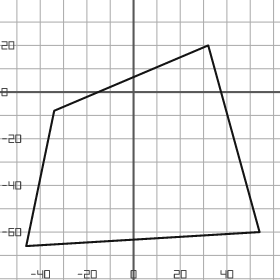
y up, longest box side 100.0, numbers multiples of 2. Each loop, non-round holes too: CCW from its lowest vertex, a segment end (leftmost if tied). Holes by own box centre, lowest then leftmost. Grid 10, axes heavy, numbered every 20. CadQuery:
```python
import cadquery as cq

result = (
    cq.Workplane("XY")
    .moveTo(-46.0, -66.0)
    .lineTo(54.0, -60.0)
    .lineTo(32.0, 20.0)
    .lineTo(-34.0, -8.0)
    .close()
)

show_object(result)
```